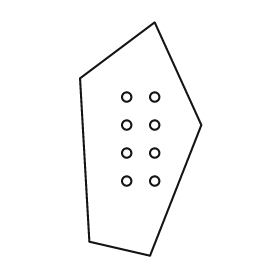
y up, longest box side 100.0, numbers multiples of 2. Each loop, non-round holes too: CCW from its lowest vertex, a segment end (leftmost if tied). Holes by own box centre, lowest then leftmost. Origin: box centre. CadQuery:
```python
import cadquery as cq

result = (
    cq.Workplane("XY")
    .moveTo(4.0, -50.0)
    .lineTo(26.0, 6.0)
    .lineTo(6.0, 50.0)
    .lineTo(-26.0, 26.0)
    .lineTo(-22.0, -44.0)
    .close()
    .moveTo(-6.0, -18.0)
    .circle(2.0)
    .moveTo(6.0, -18.0)
    .circle(2.0)
    .moveTo(-6.0, -6.0)
    .circle(2.0)
    .moveTo(6.0, -6.0)
    .circle(2.0)
    .moveTo(-6.0, 6.0)
    .circle(2.0)
    .moveTo(6.0, 6.0)
    .circle(2.0)
    .moveTo(-6.0, 18.0)
    .circle(2.0)
    .moveTo(6.0, 18.0)
    .circle(2.0)
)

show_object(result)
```